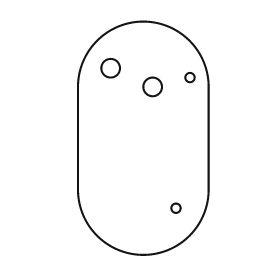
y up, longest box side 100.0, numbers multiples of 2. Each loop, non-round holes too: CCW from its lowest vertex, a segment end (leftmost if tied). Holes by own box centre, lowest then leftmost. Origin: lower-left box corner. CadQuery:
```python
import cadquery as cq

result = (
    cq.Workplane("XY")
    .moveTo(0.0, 28.0)
    .threePointArc((28.0, 0.0), (56.0, 28.0))
    .lineTo(56.0, 72.0)
    .threePointArc((28.0, 100.0), (0.0, 72.0))
    .close()
    .moveTo(42.0, 20.0)
    .circle(2.0)
    .moveTo(32.0, 72.0)
    .circle(4.0)
    .moveTo(48.0, 76.0)
    .circle(2.0)
    .moveTo(14.0, 80.0)
    .circle(4.0)
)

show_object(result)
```